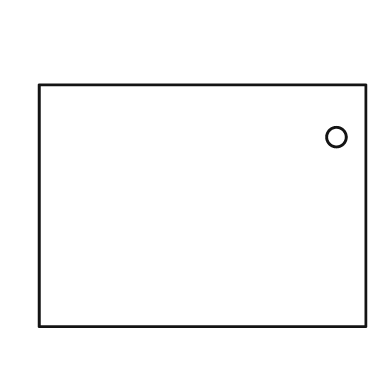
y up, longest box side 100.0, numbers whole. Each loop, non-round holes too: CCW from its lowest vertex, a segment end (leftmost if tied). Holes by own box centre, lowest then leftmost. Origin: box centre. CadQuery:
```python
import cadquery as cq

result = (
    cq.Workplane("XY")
    .moveTo(-50.0, -37.0)
    .lineTo(50.0, -37.0)
    .lineTo(50.0, 37.0)
    .lineTo(-50.0, 37.0)
    .close()
    .moveTo(41.0, 21.0)
    .circle(3.0)
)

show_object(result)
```